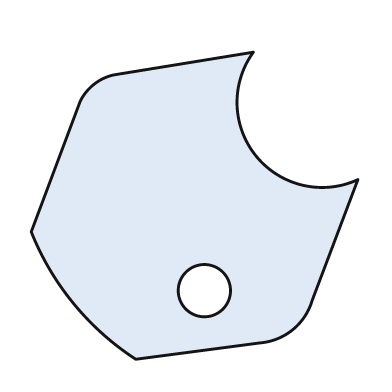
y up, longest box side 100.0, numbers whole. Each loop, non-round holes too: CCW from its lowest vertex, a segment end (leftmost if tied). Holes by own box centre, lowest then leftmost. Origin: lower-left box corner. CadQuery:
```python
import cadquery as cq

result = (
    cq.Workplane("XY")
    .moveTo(32.0, 0.0)
    .lineTo(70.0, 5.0)
    .threePointArc((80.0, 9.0), (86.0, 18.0))
    .lineTo(100.0, 55.0)
    .threePointArc((69.0, 62.0), (68.0, 94.0))
    .lineTo(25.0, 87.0)
    .threePointArc((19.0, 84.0), (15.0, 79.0))
    .lineTo(0.0, 39.0)
    .threePointArc((13.0, 17.0), (32.0, 0.0))
    .close()
    .moveTo(53.0, 21.0)
    .circle(8.0)
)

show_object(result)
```